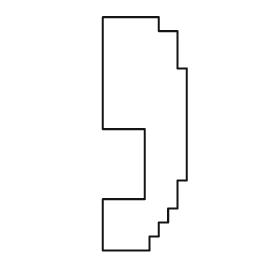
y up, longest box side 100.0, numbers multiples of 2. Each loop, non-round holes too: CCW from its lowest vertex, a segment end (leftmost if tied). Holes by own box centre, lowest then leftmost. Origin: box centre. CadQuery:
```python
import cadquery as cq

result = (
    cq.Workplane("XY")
    .moveTo(-18.0, -50.0)
    .lineTo(2.0, -50.0)
    .lineTo(2.0, -44.0)
    .lineTo(6.0, -44.0)
    .lineTo(6.0, -38.0)
    .lineTo(10.0, -38.0)
    .lineTo(10.0, -32.0)
    .lineTo(14.0, -32.0)
    .lineTo(14.0, -20.0)
    .lineTo(18.0, -20.0)
    .lineTo(18.0, 28.0)
    .lineTo(14.0, 28.0)
    .lineTo(14.0, 44.0)
    .lineTo(6.0, 44.0)
    .lineTo(6.0, 50.0)
    .lineTo(-18.0, 50.0)
    .lineTo(-18.0, 2.0)
    .lineTo(0.0, 2.0)
    .lineTo(0.0, -28.0)
    .lineTo(-18.0, -28.0)
    .close()
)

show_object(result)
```